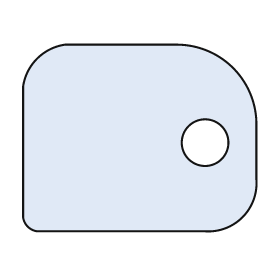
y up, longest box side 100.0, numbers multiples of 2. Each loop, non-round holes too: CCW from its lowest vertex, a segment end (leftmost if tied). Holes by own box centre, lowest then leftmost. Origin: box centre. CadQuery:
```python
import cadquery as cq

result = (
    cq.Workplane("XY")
    .moveTo(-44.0, -40.0)
    .lineTo(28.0, -40.0)
    .threePointArc((44.0, -34.0), (50.0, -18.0))
    .lineTo(50.0, 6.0)
    .threePointArc((40.0, 30.0), (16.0, 40.0))
    .lineTo(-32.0, 40.0)
    .threePointArc((-44.0, 34.0), (-50.0, 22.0))
    .lineTo(-50.0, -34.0)
    .threePointArc((-48.0, -38.0), (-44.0, -40.0))
    .close()
    .moveTo(28.0, -2.0)
    .circle(10.0)
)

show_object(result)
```